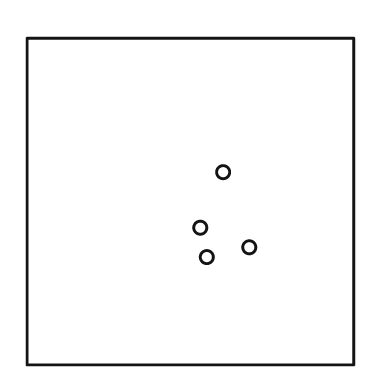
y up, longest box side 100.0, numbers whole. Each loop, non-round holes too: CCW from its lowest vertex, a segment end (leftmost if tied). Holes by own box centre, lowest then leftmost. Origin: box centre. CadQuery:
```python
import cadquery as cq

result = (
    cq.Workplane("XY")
    .moveTo(-50.0, -50.0)
    .lineTo(50.0, -50.0)
    .lineTo(50.0, 50.0)
    .lineTo(-50.0, 50.0)
    .close()
    .moveTo(5.0, -17.0)
    .circle(2.0)
    .moveTo(18.0, -14.0)
    .circle(2.0)
    .moveTo(3.0, -8.0)
    .circle(2.0)
    .moveTo(10.0, 9.0)
    .circle(2.0)
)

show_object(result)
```